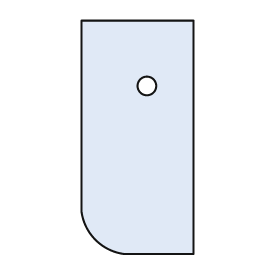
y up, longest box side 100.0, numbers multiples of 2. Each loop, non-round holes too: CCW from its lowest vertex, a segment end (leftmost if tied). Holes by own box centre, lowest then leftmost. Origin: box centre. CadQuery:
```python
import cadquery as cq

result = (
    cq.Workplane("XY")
    .moveTo(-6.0, -50.0)
    .lineTo(24.0, -50.0)
    .lineTo(24.0, 50.0)
    .lineTo(-24.0, 50.0)
    .lineTo(-24.0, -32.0)
    .threePointArc((-18.0, -44.0), (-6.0, -50.0))
    .close()
    .moveTo(4.0, 22.0)
    .circle(4.0)
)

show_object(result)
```